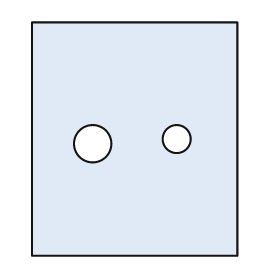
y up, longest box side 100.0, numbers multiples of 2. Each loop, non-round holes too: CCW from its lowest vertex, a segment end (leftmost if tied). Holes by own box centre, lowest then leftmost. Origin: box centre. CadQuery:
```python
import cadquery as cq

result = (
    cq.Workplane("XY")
    .moveTo(-44.0, -50.0)
    .lineTo(44.0, -50.0)
    .lineTo(44.0, 50.0)
    .lineTo(-44.0, 50.0)
    .close()
    .moveTo(-18.0, -2.0)
    .circle(8.0)
    .moveTo(18.0, 0.0)
    .circle(6.0)
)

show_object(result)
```